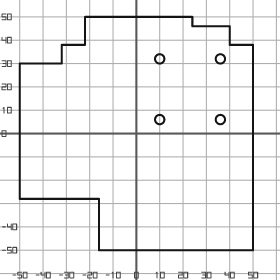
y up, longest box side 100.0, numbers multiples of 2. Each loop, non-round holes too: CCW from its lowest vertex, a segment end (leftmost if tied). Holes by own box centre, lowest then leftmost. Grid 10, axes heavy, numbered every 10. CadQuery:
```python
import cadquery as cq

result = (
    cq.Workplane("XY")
    .moveTo(-16.0, -50.0)
    .lineTo(50.0, -50.0)
    .lineTo(50.0, 38.0)
    .lineTo(40.0, 38.0)
    .lineTo(40.0, 46.0)
    .lineTo(24.0, 46.0)
    .lineTo(24.0, 50.0)
    .lineTo(-22.0, 50.0)
    .lineTo(-22.0, 38.0)
    .lineTo(-32.0, 38.0)
    .lineTo(-32.0, 30.0)
    .lineTo(-50.0, 30.0)
    .lineTo(-50.0, -28.0)
    .lineTo(-16.0, -28.0)
    .close()
    .moveTo(10.0, 6.0)
    .circle(2.0)
    .moveTo(36.0, 6.0)
    .circle(2.0)
    .moveTo(10.0, 32.0)
    .circle(2.0)
    .moveTo(36.0, 32.0)
    .circle(2.0)
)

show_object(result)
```